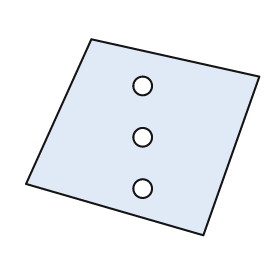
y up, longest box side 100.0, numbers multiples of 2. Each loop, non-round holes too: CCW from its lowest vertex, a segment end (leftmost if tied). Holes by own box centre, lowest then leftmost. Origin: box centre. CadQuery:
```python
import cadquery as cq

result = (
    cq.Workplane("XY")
    .moveTo(26.0, -42.0)
    .lineTo(50.0, 26.0)
    .lineTo(-22.0, 42.0)
    .lineTo(-50.0, -20.0)
    .close()
    .moveTo(0.0, -22.0)
    .circle(4.0)
    .moveTo(0.0, 0.0)
    .circle(4.0)
    .moveTo(0.0, 22.0)
    .circle(4.0)
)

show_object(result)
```